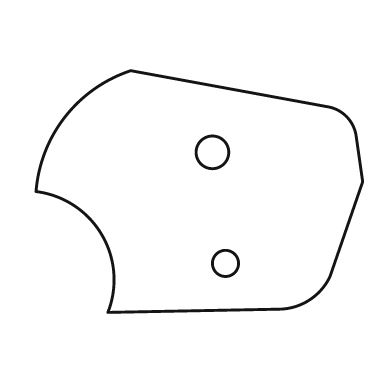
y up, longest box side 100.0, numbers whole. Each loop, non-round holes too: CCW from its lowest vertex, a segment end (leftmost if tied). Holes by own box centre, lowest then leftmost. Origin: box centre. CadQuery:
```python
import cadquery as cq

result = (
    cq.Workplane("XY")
    .moveTo(-28.0, -37.0)
    .lineTo(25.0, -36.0)
    .threePointArc((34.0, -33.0), (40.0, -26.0))
    .lineTo(50.0, 3.0)
    .lineTo(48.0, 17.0)
    .threePointArc((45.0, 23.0), (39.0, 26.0))
    .lineTo(-21.0, 37.0)
    .threePointArc((-41.0, 23.0), (-50.0, 0.0))
    .threePointArc((-30.0, -13.0), (-28.0, -37.0))
    .close()
    .moveTo(8.0, -22.0)
    .circle(4.0)
    .moveTo(4.0, 12.0)
    .circle(5.0)
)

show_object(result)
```